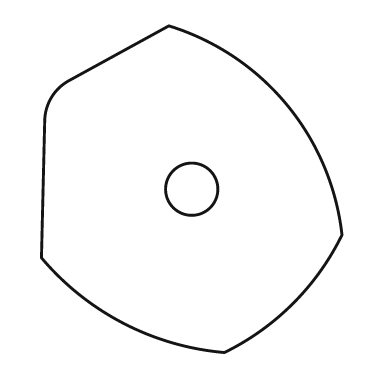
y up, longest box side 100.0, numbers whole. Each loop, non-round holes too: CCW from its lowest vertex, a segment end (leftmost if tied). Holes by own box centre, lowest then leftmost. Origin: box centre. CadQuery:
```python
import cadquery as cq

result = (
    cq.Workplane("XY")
    .moveTo(10.0, -50.0)
    .threePointArc((31.0, -35.0), (46.0, -14.0))
    .threePointArc((29.0, 26.0), (-7.0, 50.0))
    .lineTo(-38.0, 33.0)
    .threePointArc((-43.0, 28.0), (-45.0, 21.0))
    .lineTo(-46.0, -21.0)
    .threePointArc((-21.0, -41.0), (10.0, -50.0))
    .close()
    .moveTo(0.0, 0.0)
    .circle(8.0)
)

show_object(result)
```